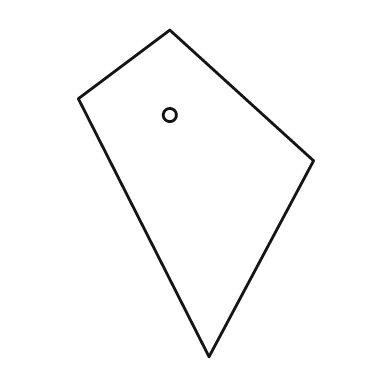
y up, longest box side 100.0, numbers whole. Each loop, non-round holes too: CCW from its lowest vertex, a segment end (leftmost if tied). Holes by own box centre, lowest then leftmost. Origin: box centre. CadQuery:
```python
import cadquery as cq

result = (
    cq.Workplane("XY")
    .moveTo(4.0, -50.0)
    .lineTo(36.0, 10.0)
    .lineTo(-8.0, 50.0)
    .lineTo(-36.0, 29.0)
    .close()
    .moveTo(-8.0, 24.0)
    .circle(2.0)
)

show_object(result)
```